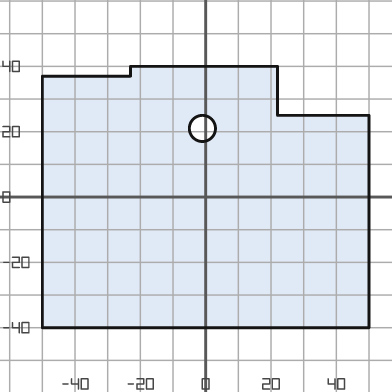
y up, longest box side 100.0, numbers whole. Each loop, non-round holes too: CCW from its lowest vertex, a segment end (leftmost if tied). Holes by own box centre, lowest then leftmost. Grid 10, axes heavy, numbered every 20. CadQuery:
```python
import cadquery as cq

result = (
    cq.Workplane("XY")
    .moveTo(-50.0, -40.0)
    .lineTo(50.0, -40.0)
    .lineTo(50.0, 25.0)
    .lineTo(22.0, 25.0)
    .lineTo(22.0, 40.0)
    .lineTo(-23.0, 40.0)
    .lineTo(-23.0, 37.0)
    .lineTo(-50.0, 37.0)
    .close()
    .moveTo(-1.0, 21.0)
    .circle(4.0)
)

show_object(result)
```